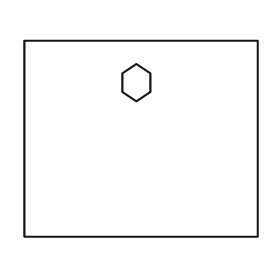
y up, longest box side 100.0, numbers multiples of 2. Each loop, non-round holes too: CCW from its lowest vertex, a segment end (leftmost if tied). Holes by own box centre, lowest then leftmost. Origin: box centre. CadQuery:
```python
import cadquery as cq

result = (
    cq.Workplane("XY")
    .moveTo(-50.0, -42.0)
    .lineTo(50.0, -42.0)
    .lineTo(50.0, 42.0)
    .lineTo(-50.0, 42.0)
    .close()
    .moveTo(-2.0, 16.0)
    .lineTo(4.0, 20.0)
    .lineTo(4.0, 28.0)
    .lineTo(-2.0, 32.0)
    .lineTo(-8.0, 28.0)
    .lineTo(-8.0, 20.0)
    .close()
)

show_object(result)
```